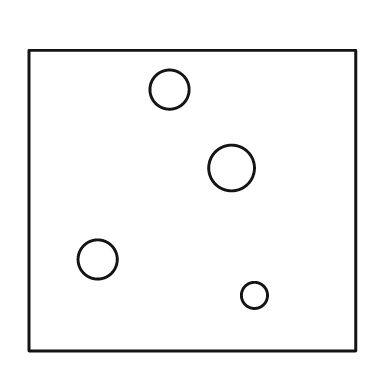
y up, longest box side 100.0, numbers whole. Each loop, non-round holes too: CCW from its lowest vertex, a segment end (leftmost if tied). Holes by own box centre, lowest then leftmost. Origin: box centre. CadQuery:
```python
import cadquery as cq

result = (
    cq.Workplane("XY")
    .moveTo(-50.0, -46.0)
    .lineTo(50.0, -46.0)
    .lineTo(50.0, 46.0)
    .lineTo(-50.0, 46.0)
    .close()
    .moveTo(19.0, -29.0)
    .circle(4.0)
    .moveTo(-29.0, -18.0)
    .circle(6.0)
    .moveTo(12.0, 10.0)
    .circle(7.0)
    .moveTo(-7.0, 34.0)
    .circle(6.0)
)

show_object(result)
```